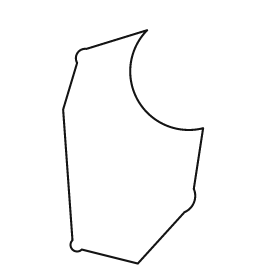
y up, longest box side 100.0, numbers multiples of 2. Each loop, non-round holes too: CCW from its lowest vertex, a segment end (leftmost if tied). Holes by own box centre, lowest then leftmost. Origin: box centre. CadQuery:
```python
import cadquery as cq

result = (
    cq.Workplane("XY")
    .moveTo(2.0, -50.0)
    .lineTo(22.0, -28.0)
    .threePointArc((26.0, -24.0), (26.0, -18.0))
    .lineTo(30.0, 8.0)
    .threePointArc((2.0, 20.0), (6.0, 50.0))
    .lineTo(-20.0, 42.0)
    .threePointArc((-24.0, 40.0), (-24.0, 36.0))
    .lineTo(-30.0, 16.0)
    .lineTo(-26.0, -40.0)
    .threePointArc((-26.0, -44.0), (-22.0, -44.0))
    .close()
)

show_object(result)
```